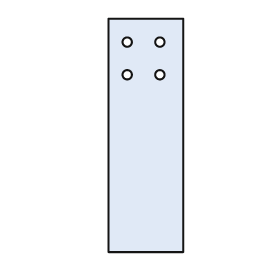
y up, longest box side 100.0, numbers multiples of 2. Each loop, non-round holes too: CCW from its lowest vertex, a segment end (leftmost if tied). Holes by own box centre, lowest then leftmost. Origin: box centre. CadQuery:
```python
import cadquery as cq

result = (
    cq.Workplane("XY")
    .moveTo(-16.0, -50.0)
    .lineTo(16.0, -50.0)
    .lineTo(16.0, 50.0)
    .lineTo(-16.0, 50.0)
    .close()
    .moveTo(-8.0, 26.0)
    .circle(2.0)
    .moveTo(6.0, 26.0)
    .circle(2.0)
    .moveTo(-8.0, 40.0)
    .circle(2.0)
    .moveTo(6.0, 40.0)
    .circle(2.0)
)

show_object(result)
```